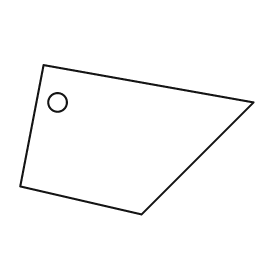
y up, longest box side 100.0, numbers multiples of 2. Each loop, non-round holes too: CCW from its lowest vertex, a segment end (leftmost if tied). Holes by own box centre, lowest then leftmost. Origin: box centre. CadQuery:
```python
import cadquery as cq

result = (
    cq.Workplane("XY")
    .moveTo(2.0, -32.0)
    .lineTo(50.0, 16.0)
    .lineTo(-40.0, 32.0)
    .lineTo(-50.0, -20.0)
    .close()
    .moveTo(-34.0, 16.0)
    .circle(4.0)
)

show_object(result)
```